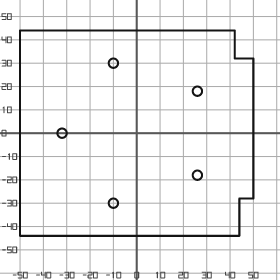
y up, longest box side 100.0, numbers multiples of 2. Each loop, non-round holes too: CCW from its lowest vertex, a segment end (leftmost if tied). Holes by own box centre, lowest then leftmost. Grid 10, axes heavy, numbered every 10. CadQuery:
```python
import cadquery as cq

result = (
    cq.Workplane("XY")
    .moveTo(-50.0, -44.0)
    .lineTo(44.0, -44.0)
    .lineTo(44.0, -28.0)
    .lineTo(50.0, -28.0)
    .lineTo(50.0, 32.0)
    .lineTo(42.0, 32.0)
    .lineTo(42.0, 44.0)
    .lineTo(-50.0, 44.0)
    .close()
    .moveTo(-10.0, -30.0)
    .circle(2.0)
    .moveTo(26.0, -18.0)
    .circle(2.0)
    .moveTo(-32.0, 0.0)
    .circle(2.0)
    .moveTo(26.0, 18.0)
    .circle(2.0)
    .moveTo(-10.0, 30.0)
    .circle(2.0)
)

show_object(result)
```